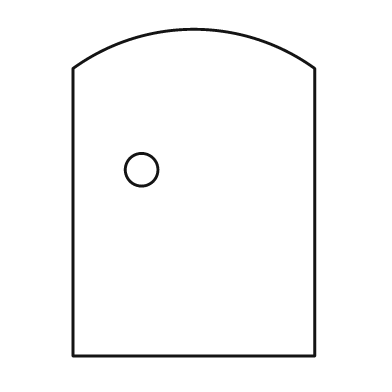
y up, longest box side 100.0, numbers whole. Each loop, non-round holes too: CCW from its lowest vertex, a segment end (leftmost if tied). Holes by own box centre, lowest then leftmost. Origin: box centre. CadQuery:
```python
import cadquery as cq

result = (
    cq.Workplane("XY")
    .moveTo(-37.0, -50.0)
    .lineTo(37.0, -50.0)
    .lineTo(37.0, 38.0)
    .threePointArc((0.0, 50.0), (-37.0, 38.0))
    .close()
    .moveTo(-16.0, 7.0)
    .circle(5.0)
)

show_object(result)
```